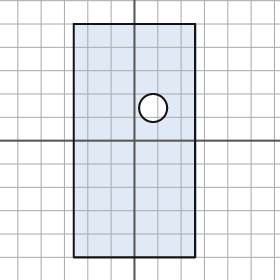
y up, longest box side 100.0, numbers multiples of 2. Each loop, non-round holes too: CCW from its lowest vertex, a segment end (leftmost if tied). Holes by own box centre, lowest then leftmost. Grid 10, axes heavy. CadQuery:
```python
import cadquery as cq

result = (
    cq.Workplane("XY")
    .moveTo(-26.0, -50.0)
    .lineTo(26.0, -50.0)
    .lineTo(26.0, 50.0)
    .lineTo(-26.0, 50.0)
    .close()
    .moveTo(8.0, 14.0)
    .circle(6.0)
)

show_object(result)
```